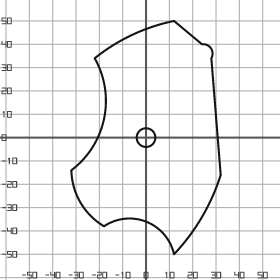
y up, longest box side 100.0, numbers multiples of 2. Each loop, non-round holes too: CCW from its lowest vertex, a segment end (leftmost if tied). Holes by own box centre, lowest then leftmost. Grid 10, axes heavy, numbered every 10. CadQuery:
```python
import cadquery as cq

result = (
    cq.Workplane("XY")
    .moveTo(12.0, -50.0)
    .threePointArc((24.0, -34.0), (32.0, -16.0))
    .lineTo(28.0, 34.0)
    .threePointArc((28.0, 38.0), (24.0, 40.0))
    .lineTo(12.0, 50.0)
    .threePointArc((-6.0, 44.0), (-22.0, 34.0))
    .threePointArc((-18.0, 8.0), (-32.0, -14.0))
    .threePointArc((-28.0, -28.0), (-18.0, -38.0))
    .threePointArc((0.0, -36.0), (12.0, -50.0))
    .close()
    .moveTo(0.0, 0.0)
    .circle(4.0)
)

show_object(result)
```